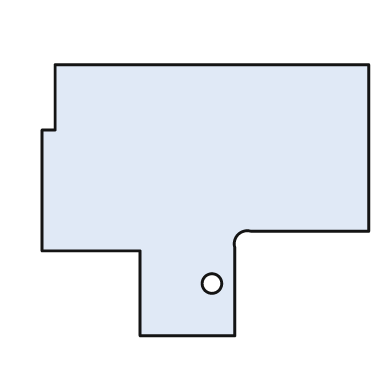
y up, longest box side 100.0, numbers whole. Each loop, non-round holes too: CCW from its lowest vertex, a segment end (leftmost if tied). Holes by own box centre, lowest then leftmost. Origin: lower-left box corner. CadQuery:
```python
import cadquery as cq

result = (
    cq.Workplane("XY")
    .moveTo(30.0, 0.0)
    .lineTo(59.0, 0.0)
    .lineTo(59.0, 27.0)
    .threePointArc((60.0, 31.0), (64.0, 32.0))
    .lineTo(100.0, 32.0)
    .lineTo(100.0, 83.0)
    .lineTo(4.0, 83.0)
    .lineTo(4.0, 63.0)
    .lineTo(0.0, 63.0)
    .lineTo(0.0, 26.0)
    .lineTo(30.0, 26.0)
    .close()
    .moveTo(52.0, 16.0)
    .circle(3.0)
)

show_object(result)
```